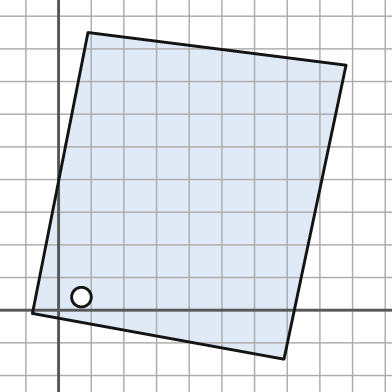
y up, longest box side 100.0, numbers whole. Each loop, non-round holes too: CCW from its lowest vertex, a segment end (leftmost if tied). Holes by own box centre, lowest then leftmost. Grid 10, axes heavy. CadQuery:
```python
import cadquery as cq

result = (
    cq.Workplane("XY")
    .moveTo(69.0, -15.0)
    .lineTo(88.0, 75.0)
    .lineTo(9.0, 85.0)
    .lineTo(-8.0, -1.0)
    .close()
    .moveTo(7.0, 4.0)
    .circle(3.0)
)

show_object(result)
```